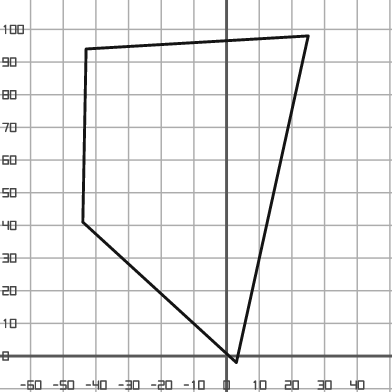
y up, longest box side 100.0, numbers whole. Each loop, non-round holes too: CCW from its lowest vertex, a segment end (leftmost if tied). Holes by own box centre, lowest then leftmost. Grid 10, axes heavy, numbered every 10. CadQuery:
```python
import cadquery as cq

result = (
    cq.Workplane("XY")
    .moveTo(3.0, -2.0)
    .lineTo(25.0, 98.0)
    .lineTo(-43.0, 94.0)
    .lineTo(-44.0, 41.0)
    .close()
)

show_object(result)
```